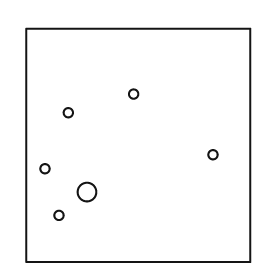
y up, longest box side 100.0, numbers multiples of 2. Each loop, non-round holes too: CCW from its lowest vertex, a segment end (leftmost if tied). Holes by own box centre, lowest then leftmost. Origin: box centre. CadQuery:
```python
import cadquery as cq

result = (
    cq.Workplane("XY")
    .moveTo(-48.0, -50.0)
    .lineTo(48.0, -50.0)
    .lineTo(48.0, 50.0)
    .lineTo(-48.0, 50.0)
    .close()
    .moveTo(-34.0, -30.0)
    .circle(2.0)
    .moveTo(-22.0, -20.0)
    .circle(4.0)
    .moveTo(-40.0, -10.0)
    .circle(2.0)
    .moveTo(32.0, -4.0)
    .circle(2.0)
    .moveTo(-30.0, 14.0)
    .circle(2.0)
    .moveTo(-2.0, 22.0)
    .circle(2.0)
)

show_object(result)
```